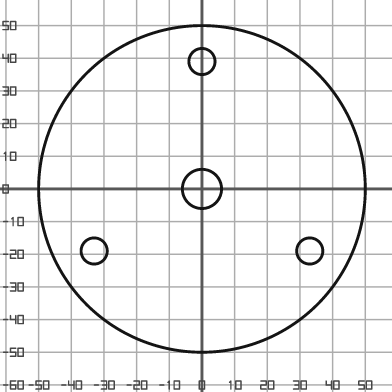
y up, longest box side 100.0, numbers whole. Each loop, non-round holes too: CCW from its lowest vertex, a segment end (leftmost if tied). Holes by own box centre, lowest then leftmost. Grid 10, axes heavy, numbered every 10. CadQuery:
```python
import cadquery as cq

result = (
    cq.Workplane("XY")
    .moveTo(0.0, 0.0)
    .circle(50.0)
    .moveTo(-33.0, -19.0)
    .circle(4.0)
    .moveTo(33.0, -19.0)
    .circle(4.0)
    .moveTo(0.0, 0.0)
    .circle(6.0)
    .moveTo(0.0, 39.0)
    .circle(4.0)
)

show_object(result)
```